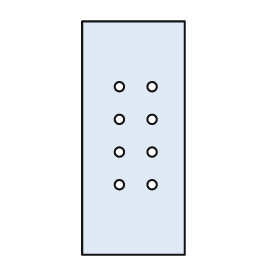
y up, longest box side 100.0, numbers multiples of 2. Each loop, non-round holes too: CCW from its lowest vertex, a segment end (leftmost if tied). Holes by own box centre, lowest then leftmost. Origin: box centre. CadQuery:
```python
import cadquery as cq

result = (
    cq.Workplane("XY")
    .moveTo(-22.0, -50.0)
    .lineTo(22.0, -50.0)
    .lineTo(22.0, 50.0)
    .lineTo(-22.0, 50.0)
    .close()
    .moveTo(-6.0, -20.0)
    .circle(2.0)
    .moveTo(8.0, -20.0)
    .circle(2.0)
    .moveTo(-6.0, -6.0)
    .circle(2.0)
    .moveTo(8.0, -6.0)
    .circle(2.0)
    .moveTo(-6.0, 8.0)
    .circle(2.0)
    .moveTo(8.0, 8.0)
    .circle(2.0)
    .moveTo(-6.0, 22.0)
    .circle(2.0)
    .moveTo(8.0, 22.0)
    .circle(2.0)
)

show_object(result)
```